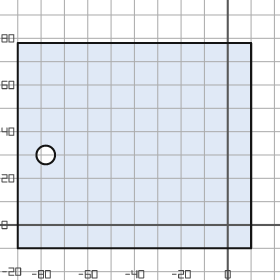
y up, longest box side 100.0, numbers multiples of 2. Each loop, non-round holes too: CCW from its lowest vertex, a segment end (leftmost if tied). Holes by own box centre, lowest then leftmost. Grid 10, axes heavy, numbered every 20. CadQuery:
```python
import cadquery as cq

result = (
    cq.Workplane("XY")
    .moveTo(-90.0, -10.0)
    .lineTo(10.0, -10.0)
    .lineTo(10.0, 78.0)
    .lineTo(-90.0, 78.0)
    .close()
    .moveTo(-78.0, 30.0)
    .circle(4.0)
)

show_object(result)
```